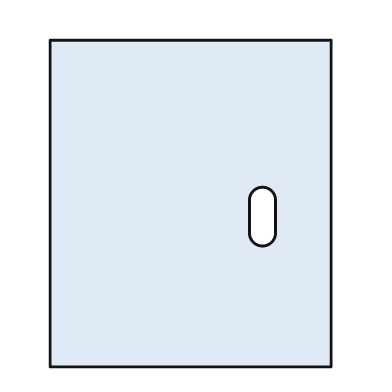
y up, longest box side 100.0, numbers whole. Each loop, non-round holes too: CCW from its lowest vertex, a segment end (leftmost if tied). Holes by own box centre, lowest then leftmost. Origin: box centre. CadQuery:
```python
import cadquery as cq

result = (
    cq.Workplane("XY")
    .moveTo(-43.0, -50.0)
    .lineTo(43.0, -50.0)
    .lineTo(43.0, 50.0)
    .lineTo(-43.0, 50.0)
    .close()
    .moveTo(18.0, -9.0)
    .threePointArc((22.0, -13.0), (26.0, -9.0))
    .lineTo(26.0, 1.0)
    .threePointArc((22.0, 5.0), (18.0, 1.0))
    .close()
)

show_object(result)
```